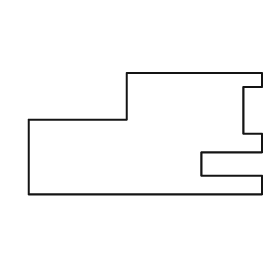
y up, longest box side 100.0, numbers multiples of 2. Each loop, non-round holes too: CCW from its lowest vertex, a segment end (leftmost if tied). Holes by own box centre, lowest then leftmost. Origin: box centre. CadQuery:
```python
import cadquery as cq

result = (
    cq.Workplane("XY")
    .moveTo(-50.0, -26.0)
    .lineTo(50.0, -26.0)
    .lineTo(50.0, -18.0)
    .lineTo(24.0, -18.0)
    .lineTo(24.0, -8.0)
    .lineTo(50.0, -8.0)
    .lineTo(50.0, 0.0)
    .lineTo(42.0, 0.0)
    .lineTo(42.0, 20.0)
    .lineTo(50.0, 20.0)
    .lineTo(50.0, 26.0)
    .lineTo(-8.0, 26.0)
    .lineTo(-8.0, 6.0)
    .lineTo(-50.0, 6.0)
    .close()
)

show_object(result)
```